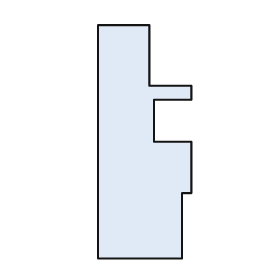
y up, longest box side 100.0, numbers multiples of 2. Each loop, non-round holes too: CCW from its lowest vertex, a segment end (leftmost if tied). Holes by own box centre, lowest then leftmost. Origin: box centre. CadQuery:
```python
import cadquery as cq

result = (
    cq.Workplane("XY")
    .moveTo(-20.0, -50.0)
    .lineTo(16.0, -50.0)
    .lineTo(16.0, -22.0)
    .lineTo(20.0, -22.0)
    .lineTo(20.0, 0.0)
    .lineTo(4.0, 0.0)
    .lineTo(4.0, 18.0)
    .lineTo(20.0, 18.0)
    .lineTo(20.0, 24.0)
    .lineTo(2.0, 24.0)
    .lineTo(2.0, 50.0)
    .lineTo(-20.0, 50.0)
    .close()
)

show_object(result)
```